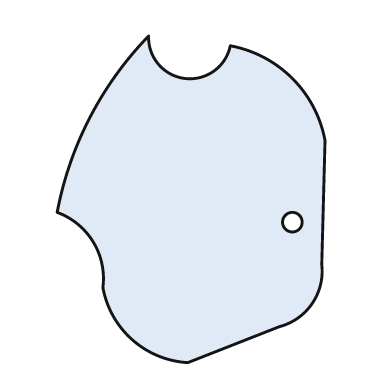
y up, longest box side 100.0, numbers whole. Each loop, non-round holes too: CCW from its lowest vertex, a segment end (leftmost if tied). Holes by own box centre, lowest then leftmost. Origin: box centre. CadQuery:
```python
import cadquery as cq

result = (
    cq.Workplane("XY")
    .moveTo(-1.0, -50.0)
    .lineTo(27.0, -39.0)
    .threePointArc((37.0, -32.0), (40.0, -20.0))
    .lineTo(41.0, 18.0)
    .threePointArc((31.0, 37.0), (12.0, 47.0))
    .threePointArc((-2.0, 37.0), (-13.0, 50.0))
    .threePointArc((-31.0, 25.0), (-41.0, -4.0))
    .threePointArc((-30.0, -13.0), (-27.0, -27.0))
    .threePointArc((-18.0, -43.0), (-1.0, -50.0))
    .close()
    .moveTo(31.0, -7.0)
    .circle(3.0)
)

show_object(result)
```